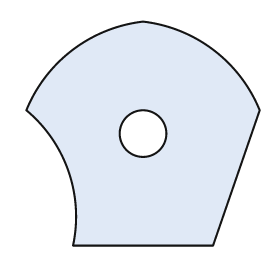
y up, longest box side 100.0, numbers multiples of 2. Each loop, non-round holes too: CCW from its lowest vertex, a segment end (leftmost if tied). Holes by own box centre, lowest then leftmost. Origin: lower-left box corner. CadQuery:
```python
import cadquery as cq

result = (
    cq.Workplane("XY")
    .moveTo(20.0, 0.0)
    .lineTo(80.0, 0.0)
    .lineTo(100.0, 58.0)
    .threePointArc((80.0, 84.0), (50.0, 96.0))
    .threePointArc((20.0, 84.0), (0.0, 58.0))
    .threePointArc((18.0, 32.0), (20.0, 0.0))
    .close()
    .moveTo(50.0, 48.0)
    .circle(10.0)
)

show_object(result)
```